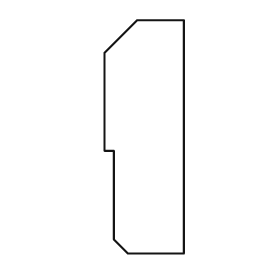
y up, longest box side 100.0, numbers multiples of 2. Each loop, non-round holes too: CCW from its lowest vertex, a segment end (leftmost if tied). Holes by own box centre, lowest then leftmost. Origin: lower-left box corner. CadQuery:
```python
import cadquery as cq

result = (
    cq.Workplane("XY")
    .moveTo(10.0, 0.0)
    .lineTo(34.0, 0.0)
    .lineTo(34.0, 100.0)
    .lineTo(14.0, 100.0)
    .lineTo(0.0, 86.0)
    .lineTo(0.0, 44.0)
    .lineTo(4.0, 44.0)
    .lineTo(4.0, 6.0)
    .close()
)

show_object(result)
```